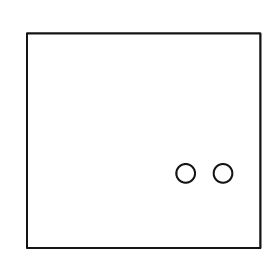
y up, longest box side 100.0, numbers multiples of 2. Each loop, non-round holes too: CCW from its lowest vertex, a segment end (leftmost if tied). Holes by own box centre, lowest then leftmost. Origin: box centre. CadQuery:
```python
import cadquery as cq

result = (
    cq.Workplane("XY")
    .moveTo(-50.0, -46.0)
    .lineTo(50.0, -46.0)
    .lineTo(50.0, 46.0)
    .lineTo(-50.0, 46.0)
    .close()
    .moveTo(18.0, -14.0)
    .circle(4.0)
    .moveTo(34.0, -14.0)
    .circle(4.0)
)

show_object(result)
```